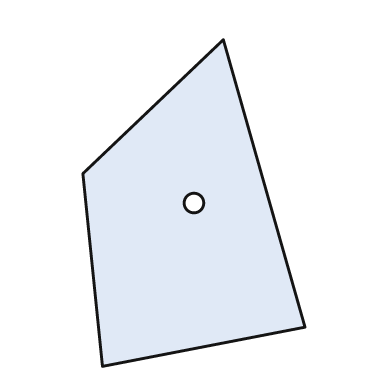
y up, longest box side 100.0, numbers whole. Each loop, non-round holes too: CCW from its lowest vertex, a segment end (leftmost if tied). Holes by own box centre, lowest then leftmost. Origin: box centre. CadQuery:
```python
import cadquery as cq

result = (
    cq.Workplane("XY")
    .moveTo(-28.0, -50.0)
    .lineTo(34.0, -38.0)
    .lineTo(9.0, 50.0)
    .lineTo(-34.0, 9.0)
    .close()
    .moveTo(0.0, 0.0)
    .circle(3.0)
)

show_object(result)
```